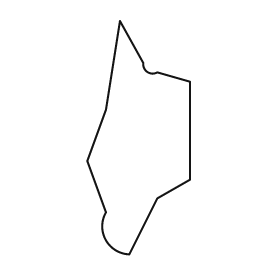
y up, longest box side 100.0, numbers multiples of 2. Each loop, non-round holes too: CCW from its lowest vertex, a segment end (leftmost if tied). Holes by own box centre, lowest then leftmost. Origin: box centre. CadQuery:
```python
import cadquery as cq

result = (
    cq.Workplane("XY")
    .moveTo(-4.0, -50.0)
    .lineTo(8.0, -26.0)
    .lineTo(22.0, -18.0)
    .lineTo(22.0, 24.0)
    .lineTo(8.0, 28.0)
    .threePointArc((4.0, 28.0), (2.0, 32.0))
    .lineTo(-8.0, 50.0)
    .lineTo(-14.0, 12.0)
    .lineTo(-22.0, -10.0)
    .lineTo(-14.0, -32.0)
    .threePointArc((-14.0, -44.0), (-4.0, -50.0))
    .close()
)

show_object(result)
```